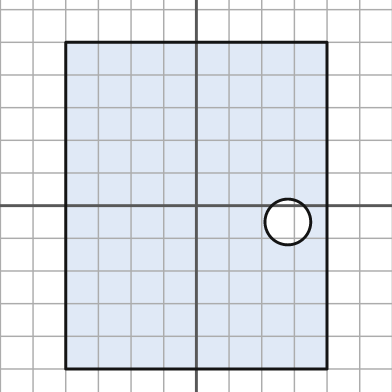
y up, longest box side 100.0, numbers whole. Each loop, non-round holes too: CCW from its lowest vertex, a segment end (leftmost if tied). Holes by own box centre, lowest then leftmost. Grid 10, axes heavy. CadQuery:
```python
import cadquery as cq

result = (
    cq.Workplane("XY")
    .moveTo(-40.0, -50.0)
    .lineTo(40.0, -50.0)
    .lineTo(40.0, 50.0)
    .lineTo(-40.0, 50.0)
    .close()
    .moveTo(28.0, -5.0)
    .circle(7.0)
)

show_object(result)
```